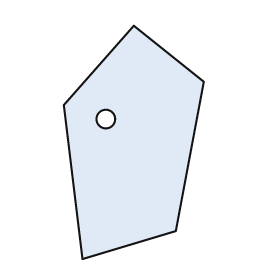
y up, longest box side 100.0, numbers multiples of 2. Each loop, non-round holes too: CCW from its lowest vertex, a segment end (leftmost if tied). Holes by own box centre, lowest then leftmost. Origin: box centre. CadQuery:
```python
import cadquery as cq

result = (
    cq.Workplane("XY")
    .moveTo(-22.0, -50.0)
    .lineTo(18.0, -38.0)
    .lineTo(30.0, 26.0)
    .lineTo(0.0, 50.0)
    .lineTo(-30.0, 16.0)
    .close()
    .moveTo(-12.0, 10.0)
    .circle(4.0)
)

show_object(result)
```